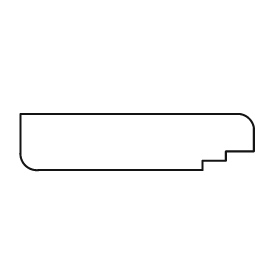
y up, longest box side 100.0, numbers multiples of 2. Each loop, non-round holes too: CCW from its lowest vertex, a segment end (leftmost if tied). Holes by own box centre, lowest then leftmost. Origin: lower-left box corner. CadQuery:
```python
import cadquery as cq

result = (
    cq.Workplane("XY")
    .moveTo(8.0, 0.0)
    .lineTo(78.0, 0.0)
    .lineTo(78.0, 4.0)
    .lineTo(88.0, 4.0)
    .lineTo(88.0, 8.0)
    .lineTo(100.0, 8.0)
    .lineTo(100.0, 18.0)
    .threePointArc((98.0, 22.0), (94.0, 24.0))
    .lineTo(0.0, 24.0)
    .lineTo(0.0, 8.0)
    .threePointArc((2.0, 2.0), (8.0, 0.0))
    .close()
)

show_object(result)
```